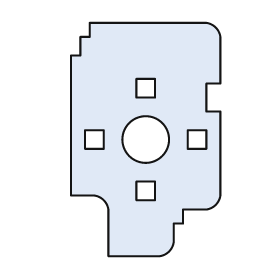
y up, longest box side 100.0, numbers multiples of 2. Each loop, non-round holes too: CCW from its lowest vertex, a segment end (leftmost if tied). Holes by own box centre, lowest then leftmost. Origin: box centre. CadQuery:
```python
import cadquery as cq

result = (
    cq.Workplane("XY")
    .moveTo(-16.0, -50.0)
    .lineTo(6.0, -50.0)
    .threePointArc((10.0, -48.0), (12.0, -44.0))
    .lineTo(12.0, -36.0)
    .lineTo(16.0, -36.0)
    .lineTo(16.0, -30.0)
    .lineTo(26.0, -30.0)
    .threePointArc((30.0, -28.0), (32.0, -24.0))
    .lineTo(32.0, 12.0)
    .lineTo(26.0, 12.0)
    .lineTo(26.0, 24.0)
    .lineTo(32.0, 24.0)
    .lineTo(32.0, 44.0)
    .threePointArc((30.0, 48.0), (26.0, 50.0))
    .lineTo(-24.0, 50.0)
    .lineTo(-24.0, 44.0)
    .lineTo(-28.0, 44.0)
    .lineTo(-28.0, 36.0)
    .lineTo(-32.0, 36.0)
    .lineTo(-32.0, -24.0)
    .lineTo(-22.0, -24.0)
    .threePointArc((-18.0, -26.0), (-16.0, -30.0))
    .close()
    .moveTo(-4.0, -26.0)
    .lineTo(4.0, -26.0)
    .lineTo(4.0, -18.0)
    .lineTo(-4.0, -18.0)
    .close()
    .moveTo(-26.0, -4.0)
    .lineTo(-18.0, -4.0)
    .lineTo(-18.0, 4.0)
    .lineTo(-26.0, 4.0)
    .close()
    .moveTo(0.0, 0.0)
    .circle(10.0)
    .moveTo(18.0, -4.0)
    .lineTo(26.0, -4.0)
    .lineTo(26.0, 4.0)
    .lineTo(18.0, 4.0)
    .close()
    .moveTo(-4.0, 18.0)
    .lineTo(4.0, 18.0)
    .lineTo(4.0, 26.0)
    .lineTo(-4.0, 26.0)
    .close()
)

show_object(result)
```